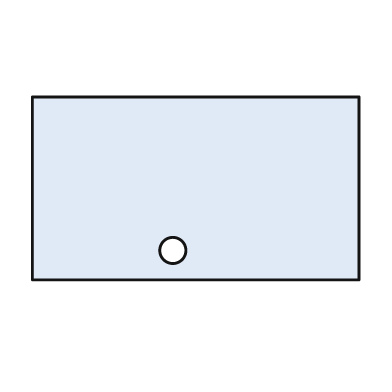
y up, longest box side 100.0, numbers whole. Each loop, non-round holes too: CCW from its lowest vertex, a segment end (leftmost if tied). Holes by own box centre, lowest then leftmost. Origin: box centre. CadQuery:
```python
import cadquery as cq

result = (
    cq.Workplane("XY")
    .moveTo(-50.0, -28.0)
    .lineTo(50.0, -28.0)
    .lineTo(50.0, 28.0)
    .lineTo(-50.0, 28.0)
    .close()
    .moveTo(-7.0, -19.0)
    .circle(4.0)
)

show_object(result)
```